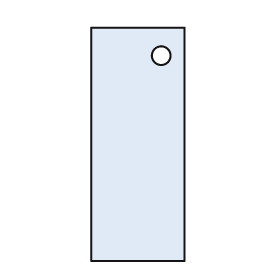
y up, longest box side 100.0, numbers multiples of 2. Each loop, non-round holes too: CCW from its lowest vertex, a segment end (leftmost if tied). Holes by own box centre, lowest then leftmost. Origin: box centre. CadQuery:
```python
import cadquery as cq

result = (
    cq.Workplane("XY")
    .moveTo(-20.0, -50.0)
    .lineTo(20.0, -50.0)
    .lineTo(20.0, 50.0)
    .lineTo(-20.0, 50.0)
    .close()
    .moveTo(10.0, 38.0)
    .circle(4.0)
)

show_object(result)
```